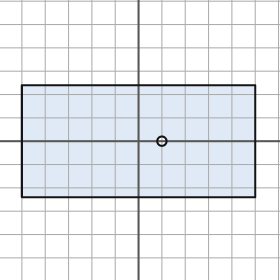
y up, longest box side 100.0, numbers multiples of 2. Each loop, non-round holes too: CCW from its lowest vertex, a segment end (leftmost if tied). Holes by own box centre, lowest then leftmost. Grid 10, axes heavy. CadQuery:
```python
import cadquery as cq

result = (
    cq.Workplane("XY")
    .moveTo(-50.0, -24.0)
    .lineTo(50.0, -24.0)
    .lineTo(50.0, 24.0)
    .lineTo(-50.0, 24.0)
    .close()
    .moveTo(10.0, 0.0)
    .circle(2.0)
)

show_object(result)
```